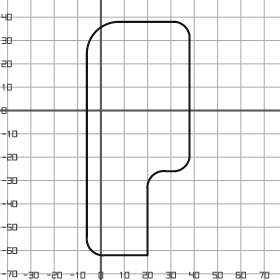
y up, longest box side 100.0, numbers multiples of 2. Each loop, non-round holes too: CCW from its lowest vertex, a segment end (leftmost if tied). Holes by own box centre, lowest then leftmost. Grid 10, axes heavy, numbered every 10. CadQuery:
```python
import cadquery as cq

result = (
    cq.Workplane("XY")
    .moveTo(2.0, -62.0)
    .lineTo(20.0, -62.0)
    .lineTo(20.0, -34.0)
    .threePointArc((22.0, -28.0), (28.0, -26.0))
    .lineTo(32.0, -26.0)
    .threePointArc((36.0, -24.0), (38.0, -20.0))
    .lineTo(38.0, 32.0)
    .threePointArc((36.0, 36.0), (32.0, 38.0))
    .lineTo(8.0, 38.0)
    .threePointArc((-2.0, 34.0), (-6.0, 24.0))
    .lineTo(-6.0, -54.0)
    .threePointArc((-4.0, -60.0), (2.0, -62.0))
    .close()
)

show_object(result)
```